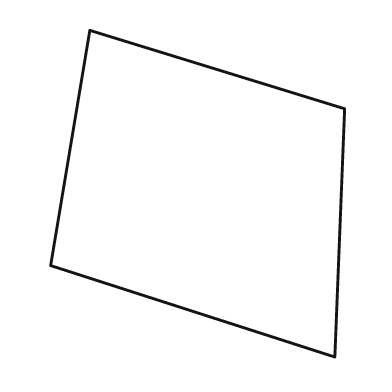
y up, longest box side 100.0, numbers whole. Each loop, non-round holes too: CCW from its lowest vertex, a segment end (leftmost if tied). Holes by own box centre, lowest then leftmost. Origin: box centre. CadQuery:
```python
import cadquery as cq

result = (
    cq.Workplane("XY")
    .moveTo(42.0, -50.0)
    .lineTo(45.0, 26.0)
    .lineTo(-33.0, 50.0)
    .lineTo(-45.0, -22.0)
    .close()
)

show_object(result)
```